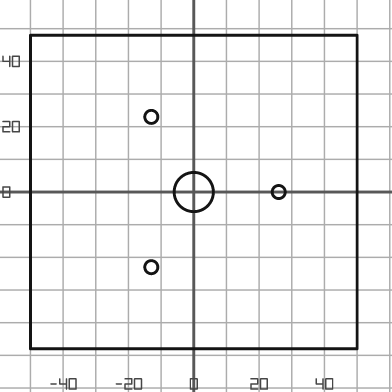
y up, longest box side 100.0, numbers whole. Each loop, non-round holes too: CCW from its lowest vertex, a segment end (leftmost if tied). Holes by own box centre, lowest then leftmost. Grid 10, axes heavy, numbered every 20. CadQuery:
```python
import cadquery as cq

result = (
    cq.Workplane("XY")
    .moveTo(-50.0, -48.0)
    .lineTo(50.0, -48.0)
    .lineTo(50.0, 48.0)
    .lineTo(-50.0, 48.0)
    .close()
    .moveTo(-13.0, -23.0)
    .circle(2.0)
    .moveTo(0.0, 0.0)
    .circle(6.0)
    .moveTo(26.0, 0.0)
    .circle(2.0)
    .moveTo(-13.0, 23.0)
    .circle(2.0)
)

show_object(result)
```